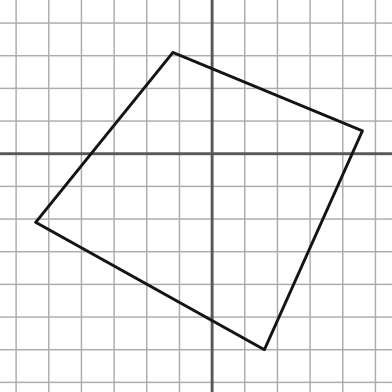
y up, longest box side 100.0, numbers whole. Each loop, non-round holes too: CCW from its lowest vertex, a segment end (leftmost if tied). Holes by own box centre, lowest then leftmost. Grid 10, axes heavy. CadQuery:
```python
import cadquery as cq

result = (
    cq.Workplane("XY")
    .moveTo(16.0, -60.0)
    .lineTo(46.0, 7.0)
    .lineTo(-12.0, 31.0)
    .lineTo(-54.0, -21.0)
    .close()
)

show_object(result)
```